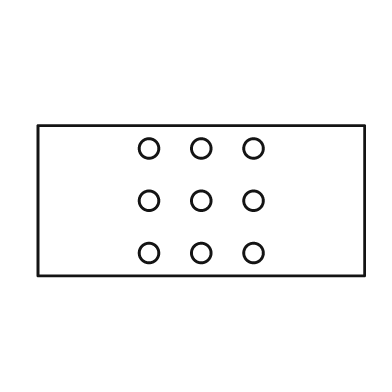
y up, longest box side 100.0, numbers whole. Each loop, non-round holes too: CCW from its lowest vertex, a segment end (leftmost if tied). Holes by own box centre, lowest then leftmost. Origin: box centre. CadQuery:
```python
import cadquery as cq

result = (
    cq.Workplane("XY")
    .moveTo(-50.0, -23.0)
    .lineTo(50.0, -23.0)
    .lineTo(50.0, 23.0)
    .lineTo(-50.0, 23.0)
    .close()
    .moveTo(-16.0, -16.0)
    .circle(3.0)
    .moveTo(0.0, -16.0)
    .circle(3.0)
    .moveTo(16.0, -16.0)
    .circle(3.0)
    .moveTo(-16.0, 0.0)
    .circle(3.0)
    .moveTo(0.0, 0.0)
    .circle(3.0)
    .moveTo(16.0, 0.0)
    .circle(3.0)
    .moveTo(-16.0, 16.0)
    .circle(3.0)
    .moveTo(0.0, 16.0)
    .circle(3.0)
    .moveTo(16.0, 16.0)
    .circle(3.0)
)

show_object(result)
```